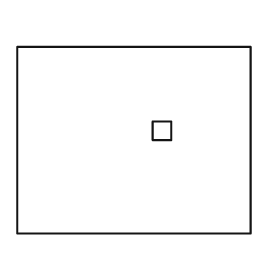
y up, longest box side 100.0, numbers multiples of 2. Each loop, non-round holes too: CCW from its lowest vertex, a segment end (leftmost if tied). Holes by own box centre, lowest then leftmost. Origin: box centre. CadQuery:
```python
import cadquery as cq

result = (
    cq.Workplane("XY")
    .moveTo(-50.0, -40.0)
    .lineTo(50.0, -40.0)
    .lineTo(50.0, 40.0)
    .lineTo(-50.0, 40.0)
    .close()
    .moveTo(8.0, 0.0)
    .lineTo(16.0, 0.0)
    .lineTo(16.0, 8.0)
    .lineTo(8.0, 8.0)
    .close()
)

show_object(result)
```